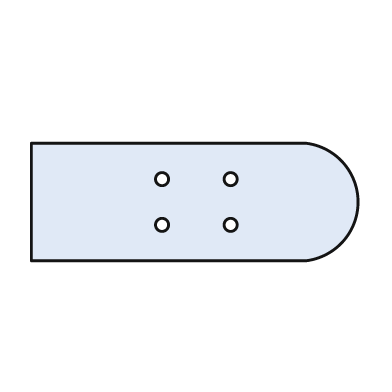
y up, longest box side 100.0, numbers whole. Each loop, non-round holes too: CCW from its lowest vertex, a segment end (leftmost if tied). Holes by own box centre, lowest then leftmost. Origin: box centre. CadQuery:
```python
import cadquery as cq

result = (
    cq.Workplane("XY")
    .moveTo(-50.0, -18.0)
    .lineTo(34.0, -18.0)
    .threePointArc((50.0, 0.0), (34.0, 18.0))
    .lineTo(-50.0, 18.0)
    .close()
    .moveTo(-10.0, -7.0)
    .circle(2.0)
    .moveTo(11.0, -7.0)
    .circle(2.0)
    .moveTo(-10.0, 7.0)
    .circle(2.0)
    .moveTo(11.0, 7.0)
    .circle(2.0)
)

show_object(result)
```